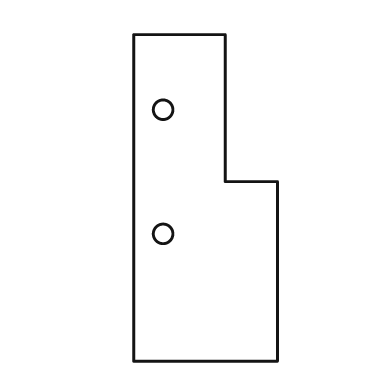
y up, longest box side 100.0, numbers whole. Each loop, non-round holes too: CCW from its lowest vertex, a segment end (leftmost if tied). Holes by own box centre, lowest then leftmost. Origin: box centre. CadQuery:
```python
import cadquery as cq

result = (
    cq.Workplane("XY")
    .moveTo(-22.0, -50.0)
    .lineTo(22.0, -50.0)
    .lineTo(22.0, 5.0)
    .lineTo(6.0, 5.0)
    .lineTo(6.0, 50.0)
    .lineTo(-22.0, 50.0)
    .close()
    .moveTo(-13.0, -11.0)
    .circle(3.0)
    .moveTo(-13.0, 27.0)
    .circle(3.0)
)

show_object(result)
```